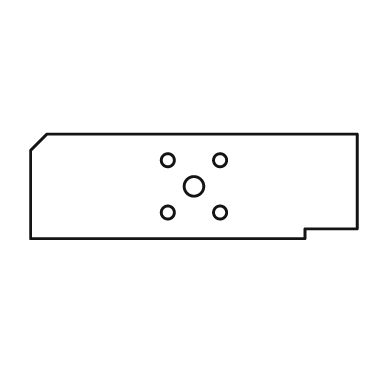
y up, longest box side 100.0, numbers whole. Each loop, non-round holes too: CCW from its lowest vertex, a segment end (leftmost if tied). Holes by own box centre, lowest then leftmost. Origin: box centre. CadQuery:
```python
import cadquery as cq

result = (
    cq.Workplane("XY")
    .moveTo(-50.0, -16.0)
    .lineTo(34.0, -16.0)
    .lineTo(34.0, -13.0)
    .lineTo(50.0, -13.0)
    .lineTo(50.0, 16.0)
    .lineTo(-45.0, 16.0)
    .lineTo(-50.0, 11.0)
    .close()
    .moveTo(-8.0, -8.0)
    .circle(2.0)
    .moveTo(8.0, -8.0)
    .circle(2.0)
    .moveTo(0.0, 0.0)
    .circle(3.0)
    .moveTo(-8.0, 8.0)
    .circle(2.0)
    .moveTo(8.0, 8.0)
    .circle(2.0)
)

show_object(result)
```